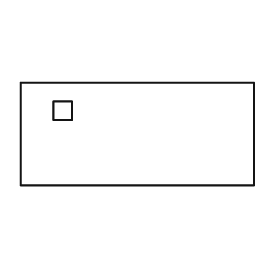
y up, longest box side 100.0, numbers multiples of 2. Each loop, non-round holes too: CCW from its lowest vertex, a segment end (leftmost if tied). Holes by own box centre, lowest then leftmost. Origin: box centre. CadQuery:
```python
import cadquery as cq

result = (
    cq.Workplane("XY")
    .moveTo(-50.0, -22.0)
    .lineTo(50.0, -22.0)
    .lineTo(50.0, 22.0)
    .lineTo(-50.0, 22.0)
    .close()
    .moveTo(-36.0, 6.0)
    .lineTo(-28.0, 6.0)
    .lineTo(-28.0, 14.0)
    .lineTo(-36.0, 14.0)
    .close()
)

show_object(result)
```